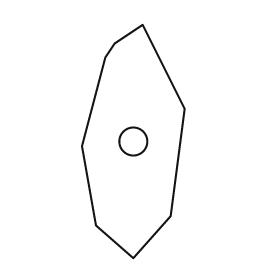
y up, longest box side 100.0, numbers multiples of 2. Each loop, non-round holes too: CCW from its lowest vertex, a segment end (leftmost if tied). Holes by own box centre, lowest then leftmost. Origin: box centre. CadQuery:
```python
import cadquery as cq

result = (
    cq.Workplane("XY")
    .moveTo(0.0, -50.0)
    .lineTo(16.0, -32.0)
    .lineTo(22.0, 14.0)
    .lineTo(4.0, 50.0)
    .lineTo(-8.0, 42.0)
    .lineTo(-12.0, 36.0)
    .lineTo(-22.0, -2.0)
    .lineTo(-16.0, -36.0)
    .close()
    .moveTo(0.0, 0.0)
    .circle(6.0)
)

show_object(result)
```